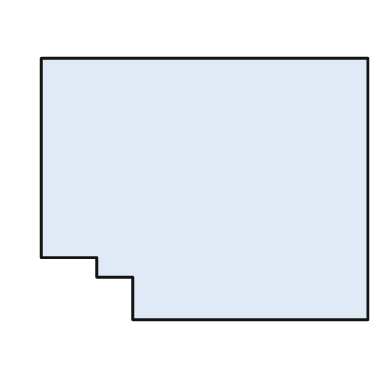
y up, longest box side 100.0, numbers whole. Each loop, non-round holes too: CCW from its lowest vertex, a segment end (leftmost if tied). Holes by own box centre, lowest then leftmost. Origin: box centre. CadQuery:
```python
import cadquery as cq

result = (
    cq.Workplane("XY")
    .moveTo(-22.0, -40.0)
    .lineTo(50.0, -40.0)
    .lineTo(50.0, 40.0)
    .lineTo(-50.0, 40.0)
    .lineTo(-50.0, -21.0)
    .lineTo(-33.0, -21.0)
    .lineTo(-33.0, -27.0)
    .lineTo(-22.0, -27.0)
    .close()
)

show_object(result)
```